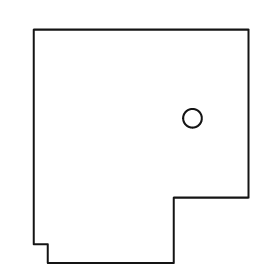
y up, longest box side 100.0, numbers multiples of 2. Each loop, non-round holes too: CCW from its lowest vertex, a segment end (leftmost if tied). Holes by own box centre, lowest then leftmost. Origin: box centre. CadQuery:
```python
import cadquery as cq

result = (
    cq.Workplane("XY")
    .moveTo(-40.0, -50.0)
    .lineTo(14.0, -50.0)
    .lineTo(14.0, -22.0)
    .lineTo(46.0, -22.0)
    .lineTo(46.0, 50.0)
    .lineTo(-46.0, 50.0)
    .lineTo(-46.0, -42.0)
    .lineTo(-40.0, -42.0)
    .close()
    .moveTo(22.0, 12.0)
    .circle(4.0)
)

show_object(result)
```